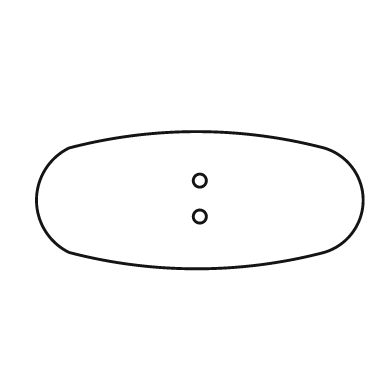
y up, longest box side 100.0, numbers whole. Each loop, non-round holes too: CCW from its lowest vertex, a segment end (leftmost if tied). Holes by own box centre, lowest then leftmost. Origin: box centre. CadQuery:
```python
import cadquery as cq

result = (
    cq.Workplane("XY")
    .moveTo(-40.0, -16.0)
    .threePointArc((-1.0, -21.0), (38.0, -16.0))
    .threePointArc((50.0, 0.0), (38.0, 16.0))
    .threePointArc((-1.0, 21.0), (-40.0, 16.0))
    .threePointArc((-50.0, 0.0), (-40.0, -16.0))
    .close()
    .moveTo(0.0, -5.0)
    .circle(2.0)
    .moveTo(0.0, 6.0)
    .circle(2.0)
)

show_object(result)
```